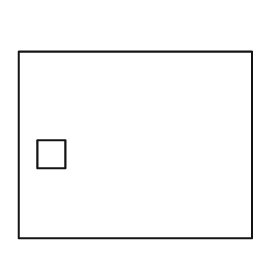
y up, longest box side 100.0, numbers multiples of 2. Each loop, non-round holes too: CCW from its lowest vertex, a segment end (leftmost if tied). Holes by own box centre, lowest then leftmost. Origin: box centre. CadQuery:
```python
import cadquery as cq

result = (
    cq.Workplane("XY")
    .moveTo(-50.0, -40.0)
    .lineTo(50.0, -40.0)
    .lineTo(50.0, 40.0)
    .lineTo(-50.0, 40.0)
    .close()
    .moveTo(-42.0, -10.0)
    .lineTo(-30.0, -10.0)
    .lineTo(-30.0, 2.0)
    .lineTo(-42.0, 2.0)
    .close()
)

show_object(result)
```